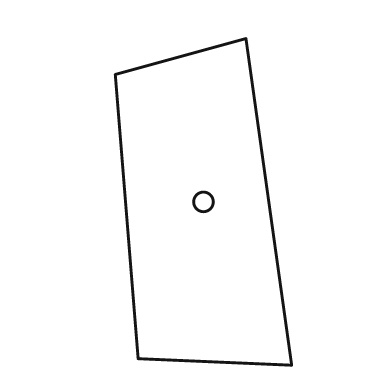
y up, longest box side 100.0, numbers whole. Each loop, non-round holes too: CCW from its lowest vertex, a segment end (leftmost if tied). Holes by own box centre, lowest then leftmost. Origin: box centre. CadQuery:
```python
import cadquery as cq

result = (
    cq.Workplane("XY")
    .moveTo(27.0, -50.0)
    .lineTo(13.0, 50.0)
    .lineTo(-27.0, 39.0)
    .lineTo(-20.0, -48.0)
    .close()
    .moveTo(0.0, 0.0)
    .circle(3.0)
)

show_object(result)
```